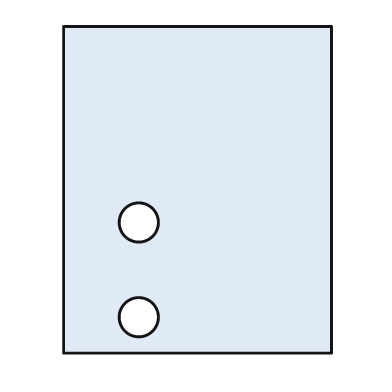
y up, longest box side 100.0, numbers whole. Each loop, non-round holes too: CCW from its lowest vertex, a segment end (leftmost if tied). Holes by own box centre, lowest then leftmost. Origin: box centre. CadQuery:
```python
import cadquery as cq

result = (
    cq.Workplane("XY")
    .moveTo(-41.0, -50.0)
    .lineTo(41.0, -50.0)
    .lineTo(41.0, 50.0)
    .lineTo(-41.0, 50.0)
    .close()
    .moveTo(-18.0, -39.0)
    .circle(6.0)
    .moveTo(-18.0, -10.0)
    .circle(6.0)
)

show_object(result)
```